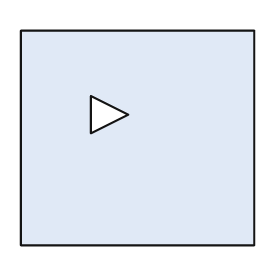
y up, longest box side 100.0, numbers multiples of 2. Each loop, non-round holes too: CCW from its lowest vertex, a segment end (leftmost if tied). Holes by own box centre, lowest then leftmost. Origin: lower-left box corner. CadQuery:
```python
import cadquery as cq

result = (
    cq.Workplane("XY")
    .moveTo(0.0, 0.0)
    .lineTo(100.0, 0.0)
    .lineTo(100.0, 92.0)
    .lineTo(0.0, 92.0)
    .close()
    .moveTo(30.0, 48.0)
    .lineTo(46.0, 56.0)
    .lineTo(30.0, 64.0)
    .close()
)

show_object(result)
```